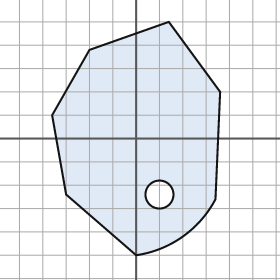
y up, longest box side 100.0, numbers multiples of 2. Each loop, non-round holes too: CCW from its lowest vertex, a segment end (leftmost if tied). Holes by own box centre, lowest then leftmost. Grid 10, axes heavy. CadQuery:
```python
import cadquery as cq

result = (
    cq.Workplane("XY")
    .moveTo(0.0, -50.0)
    .threePointArc((20.0, -42.0), (34.0, -26.0))
    .lineTo(36.0, 20.0)
    .lineTo(14.0, 50.0)
    .lineTo(-20.0, 38.0)
    .lineTo(-36.0, 10.0)
    .lineTo(-30.0, -24.0)
    .close()
    .moveTo(10.0, -24.0)
    .circle(6.0)
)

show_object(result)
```